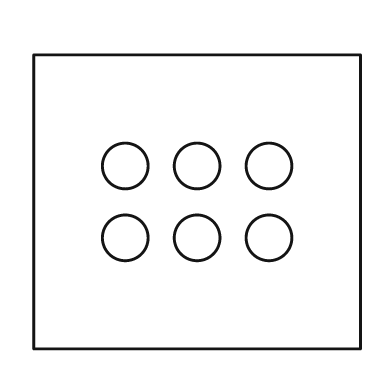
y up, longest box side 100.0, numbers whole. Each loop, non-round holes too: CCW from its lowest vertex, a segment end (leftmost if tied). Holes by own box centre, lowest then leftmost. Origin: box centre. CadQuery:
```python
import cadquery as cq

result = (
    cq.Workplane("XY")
    .moveTo(-50.0, -45.0)
    .lineTo(50.0, -45.0)
    .lineTo(50.0, 45.0)
    .lineTo(-50.0, 45.0)
    .close()
    .moveTo(-22.0, -11.0)
    .circle(7.0)
    .moveTo(0.0, -11.0)
    .circle(7.0)
    .moveTo(22.0, -11.0)
    .circle(7.0)
    .moveTo(-22.0, 11.0)
    .circle(7.0)
    .moveTo(0.0, 11.0)
    .circle(7.0)
    .moveTo(22.0, 11.0)
    .circle(7.0)
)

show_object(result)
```